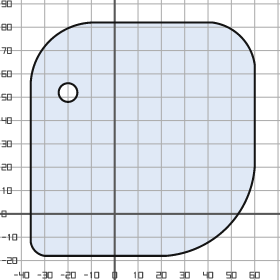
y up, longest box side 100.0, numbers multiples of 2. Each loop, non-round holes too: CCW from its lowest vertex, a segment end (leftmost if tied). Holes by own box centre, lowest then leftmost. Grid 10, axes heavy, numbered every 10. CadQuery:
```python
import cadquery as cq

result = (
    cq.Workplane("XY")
    .moveTo(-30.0, -18.0)
    .lineTo(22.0, -18.0)
    .threePointArc((48.0, -6.0), (60.0, 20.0))
    .lineTo(60.0, 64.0)
    .threePointArc((54.0, 76.0), (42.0, 82.0))
    .lineTo(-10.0, 82.0)
    .threePointArc((-28.0, 74.0), (-36.0, 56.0))
    .lineTo(-36.0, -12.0)
    .threePointArc((-34.0, -16.0), (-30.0, -18.0))
    .close()
    .moveTo(-20.0, 52.0)
    .circle(4.0)
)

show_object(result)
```